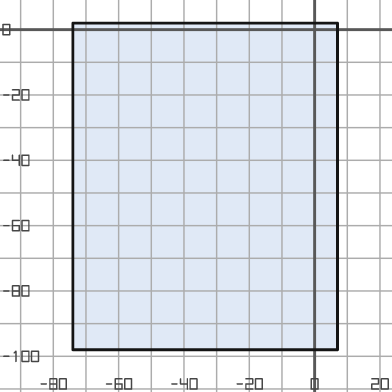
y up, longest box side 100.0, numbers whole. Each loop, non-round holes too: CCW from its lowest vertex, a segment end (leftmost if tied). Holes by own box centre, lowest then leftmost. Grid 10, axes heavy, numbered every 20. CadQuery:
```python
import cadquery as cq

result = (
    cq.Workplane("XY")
    .moveTo(-74.0, -98.0)
    .lineTo(7.0, -98.0)
    .lineTo(7.0, 2.0)
    .lineTo(-74.0, 2.0)
    .close()
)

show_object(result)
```